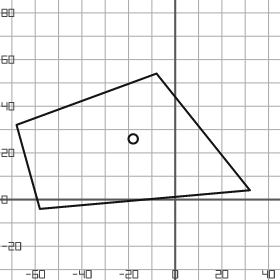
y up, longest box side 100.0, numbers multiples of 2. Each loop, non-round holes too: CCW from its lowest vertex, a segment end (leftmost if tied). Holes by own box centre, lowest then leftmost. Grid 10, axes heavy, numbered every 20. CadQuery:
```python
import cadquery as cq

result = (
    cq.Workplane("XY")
    .moveTo(-58.0, -4.0)
    .lineTo(32.0, 4.0)
    .lineTo(-8.0, 54.0)
    .lineTo(-68.0, 32.0)
    .close()
    .moveTo(-18.0, 26.0)
    .circle(2.0)
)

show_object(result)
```